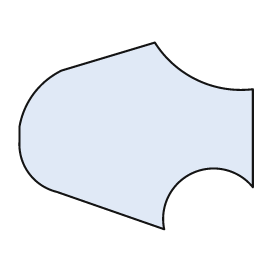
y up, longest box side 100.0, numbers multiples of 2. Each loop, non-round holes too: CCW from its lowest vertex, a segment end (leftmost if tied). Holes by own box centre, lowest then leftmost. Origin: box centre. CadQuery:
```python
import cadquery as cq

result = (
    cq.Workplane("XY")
    .moveTo(12.0, -40.0)
    .threePointArc((24.0, -16.0), (50.0, -22.0))
    .lineTo(50.0, 20.0)
    .threePointArc((26.0, 24.0), (8.0, 40.0))
    .lineTo(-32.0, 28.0)
    .threePointArc((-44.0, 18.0), (-50.0, 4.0))
    .lineTo(-50.0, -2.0)
    .threePointArc((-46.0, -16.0), (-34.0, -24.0))
    .close()
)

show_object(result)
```